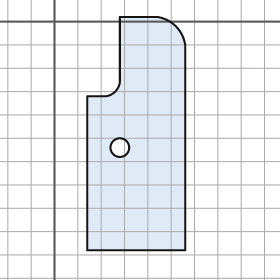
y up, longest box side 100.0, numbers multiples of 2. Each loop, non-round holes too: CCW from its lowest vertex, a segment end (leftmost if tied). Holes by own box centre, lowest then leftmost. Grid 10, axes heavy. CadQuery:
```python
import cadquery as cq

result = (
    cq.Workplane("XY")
    .moveTo(14.0, -98.0)
    .lineTo(56.0, -98.0)
    .lineTo(56.0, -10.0)
    .threePointArc((52.0, -2.0), (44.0, 2.0))
    .lineTo(28.0, 2.0)
    .lineTo(28.0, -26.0)
    .threePointArc((26.0, -30.0), (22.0, -32.0))
    .lineTo(14.0, -32.0)
    .close()
    .moveTo(28.0, -54.0)
    .circle(4.0)
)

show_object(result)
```